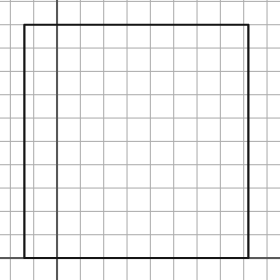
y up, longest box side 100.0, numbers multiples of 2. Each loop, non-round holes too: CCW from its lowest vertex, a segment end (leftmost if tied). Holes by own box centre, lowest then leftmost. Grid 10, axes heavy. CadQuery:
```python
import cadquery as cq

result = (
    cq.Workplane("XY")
    .moveTo(-14.0, 0.0)
    .lineTo(82.0, 0.0)
    .lineTo(82.0, 100.0)
    .lineTo(-14.0, 100.0)
    .close()
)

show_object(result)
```